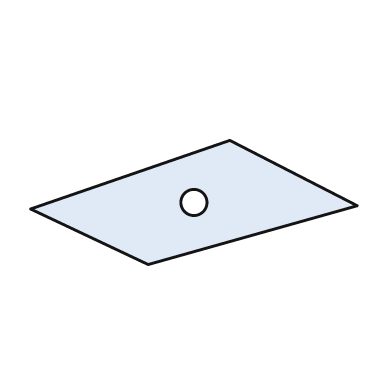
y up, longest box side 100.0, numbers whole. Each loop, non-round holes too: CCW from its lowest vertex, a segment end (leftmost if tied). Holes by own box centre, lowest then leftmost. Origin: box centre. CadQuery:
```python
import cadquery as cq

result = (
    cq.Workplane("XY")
    .moveTo(-14.0, -19.0)
    .lineTo(50.0, -1.0)
    .lineTo(11.0, 19.0)
    .lineTo(-50.0, -2.0)
    .close()
    .moveTo(0.0, 0.0)
    .circle(4.0)
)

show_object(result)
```